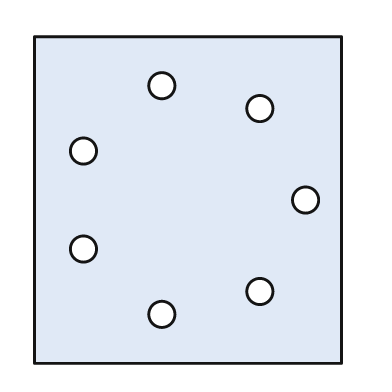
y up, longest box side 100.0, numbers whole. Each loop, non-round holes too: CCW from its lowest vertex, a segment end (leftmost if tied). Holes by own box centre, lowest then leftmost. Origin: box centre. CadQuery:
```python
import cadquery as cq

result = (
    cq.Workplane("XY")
    .moveTo(-47.0, -50.0)
    .lineTo(47.0, -50.0)
    .lineTo(47.0, 50.0)
    .lineTo(-47.0, 50.0)
    .close()
    .moveTo(-8.0, -35.0)
    .circle(4.0)
    .moveTo(22.0, -28.0)
    .circle(4.0)
    .moveTo(-32.0, -15.0)
    .circle(4.0)
    .moveTo(36.0, 0.0)
    .circle(4.0)
    .moveTo(-32.0, 15.0)
    .circle(4.0)
    .moveTo(22.0, 28.0)
    .circle(4.0)
    .moveTo(-8.0, 35.0)
    .circle(4.0)
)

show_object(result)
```